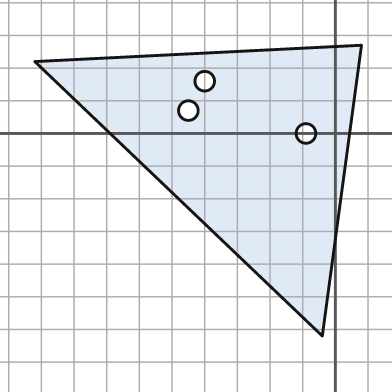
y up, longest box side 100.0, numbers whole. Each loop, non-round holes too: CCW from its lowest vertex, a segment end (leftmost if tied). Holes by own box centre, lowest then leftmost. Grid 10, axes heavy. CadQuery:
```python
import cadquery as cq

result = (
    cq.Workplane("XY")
    .moveTo(-4.0, -62.0)
    .lineTo(8.0, 27.0)
    .lineTo(-92.0, 22.0)
    .close()
    .moveTo(-9.0, 0.0)
    .circle(3.0)
    .moveTo(-45.0, 7.0)
    .circle(3.0)
    .moveTo(-40.0, 16.0)
    .circle(3.0)
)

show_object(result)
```